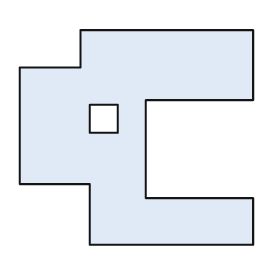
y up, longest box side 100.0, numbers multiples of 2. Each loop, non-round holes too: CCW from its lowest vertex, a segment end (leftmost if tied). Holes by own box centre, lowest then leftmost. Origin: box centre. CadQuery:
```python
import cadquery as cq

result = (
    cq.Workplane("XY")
    .moveTo(-20.0, -46.0)
    .lineTo(50.0, -46.0)
    .lineTo(50.0, -26.0)
    .lineTo(4.0, -26.0)
    .lineTo(4.0, 16.0)
    .lineTo(50.0, 16.0)
    .lineTo(50.0, 46.0)
    .lineTo(-24.0, 46.0)
    .lineTo(-24.0, 30.0)
    .lineTo(-50.0, 30.0)
    .lineTo(-50.0, -20.0)
    .lineTo(-20.0, -20.0)
    .close()
    .moveTo(-20.0, 2.0)
    .lineTo(-8.0, 2.0)
    .lineTo(-8.0, 14.0)
    .lineTo(-20.0, 14.0)
    .close()
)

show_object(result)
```